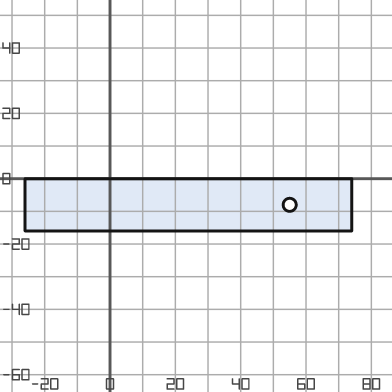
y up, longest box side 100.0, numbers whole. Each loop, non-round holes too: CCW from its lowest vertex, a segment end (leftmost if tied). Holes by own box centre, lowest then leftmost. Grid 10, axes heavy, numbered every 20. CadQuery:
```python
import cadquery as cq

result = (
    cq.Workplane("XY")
    .moveTo(-26.0, -16.0)
    .lineTo(74.0, -16.0)
    .lineTo(74.0, 0.0)
    .lineTo(-26.0, 0.0)
    .close()
    .moveTo(55.0, -8.0)
    .circle(2.0)
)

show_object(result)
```